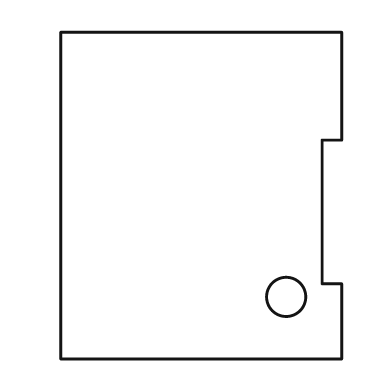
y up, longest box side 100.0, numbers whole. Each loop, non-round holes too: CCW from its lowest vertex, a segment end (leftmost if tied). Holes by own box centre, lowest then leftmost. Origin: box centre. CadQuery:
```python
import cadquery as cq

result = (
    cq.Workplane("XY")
    .moveTo(-43.0, -50.0)
    .lineTo(43.0, -50.0)
    .lineTo(43.0, -27.0)
    .lineTo(37.0, -27.0)
    .lineTo(37.0, 17.0)
    .lineTo(43.0, 17.0)
    .lineTo(43.0, 50.0)
    .lineTo(-43.0, 50.0)
    .close()
    .moveTo(26.0, -31.0)
    .circle(6.0)
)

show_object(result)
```